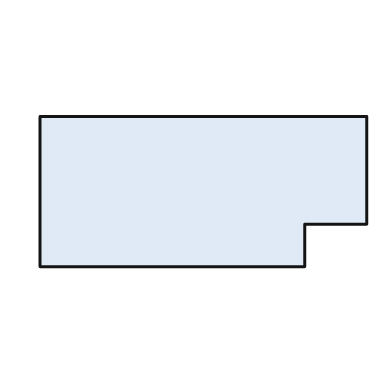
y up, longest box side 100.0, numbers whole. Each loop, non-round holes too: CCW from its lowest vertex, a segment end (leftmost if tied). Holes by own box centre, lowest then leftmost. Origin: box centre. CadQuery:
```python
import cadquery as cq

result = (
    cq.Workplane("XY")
    .moveTo(-50.0, -23.0)
    .lineTo(31.0, -23.0)
    .lineTo(31.0, -10.0)
    .lineTo(50.0, -10.0)
    .lineTo(50.0, 23.0)
    .lineTo(-50.0, 23.0)
    .close()
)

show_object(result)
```